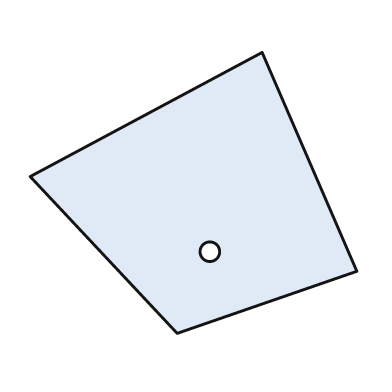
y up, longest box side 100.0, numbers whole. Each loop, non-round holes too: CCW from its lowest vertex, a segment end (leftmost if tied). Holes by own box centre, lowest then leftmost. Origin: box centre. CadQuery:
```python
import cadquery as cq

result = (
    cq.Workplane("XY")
    .moveTo(-5.0, -43.0)
    .lineTo(50.0, -24.0)
    .lineTo(21.0, 43.0)
    .lineTo(-50.0, 5.0)
    .close()
    .moveTo(5.0, -18.0)
    .circle(3.0)
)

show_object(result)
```